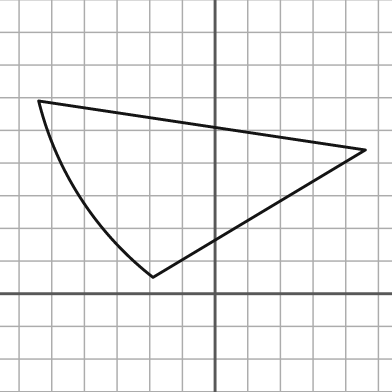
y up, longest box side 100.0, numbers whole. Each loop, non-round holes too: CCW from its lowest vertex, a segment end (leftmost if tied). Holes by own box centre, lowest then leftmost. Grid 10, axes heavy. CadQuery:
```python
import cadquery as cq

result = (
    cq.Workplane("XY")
    .moveTo(-19.0, 5.0)
    .lineTo(46.0, 44.0)
    .lineTo(-54.0, 59.0)
    .threePointArc((-41.0, 29.0), (-19.0, 5.0))
    .close()
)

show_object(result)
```